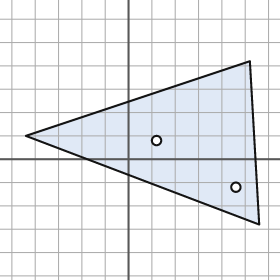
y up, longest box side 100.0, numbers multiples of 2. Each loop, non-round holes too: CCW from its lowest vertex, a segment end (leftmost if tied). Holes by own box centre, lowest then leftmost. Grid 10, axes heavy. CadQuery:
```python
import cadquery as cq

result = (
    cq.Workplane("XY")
    .moveTo(56.0, -28.0)
    .lineTo(52.0, 42.0)
    .lineTo(-44.0, 10.0)
    .close()
    .moveTo(46.0, -12.0)
    .circle(2.0)
    .moveTo(12.0, 8.0)
    .circle(2.0)
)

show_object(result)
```